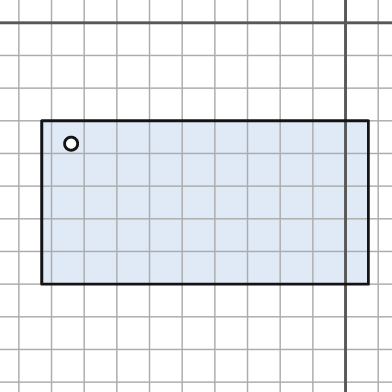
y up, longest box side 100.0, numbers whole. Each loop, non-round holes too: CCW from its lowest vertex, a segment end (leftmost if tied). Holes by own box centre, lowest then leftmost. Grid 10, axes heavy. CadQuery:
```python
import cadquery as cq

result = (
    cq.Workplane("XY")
    .moveTo(-93.0, -80.0)
    .lineTo(7.0, -80.0)
    .lineTo(7.0, -30.0)
    .lineTo(-93.0, -30.0)
    .close()
    .moveTo(-84.0, -37.0)
    .circle(2.0)
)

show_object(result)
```